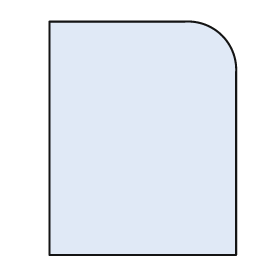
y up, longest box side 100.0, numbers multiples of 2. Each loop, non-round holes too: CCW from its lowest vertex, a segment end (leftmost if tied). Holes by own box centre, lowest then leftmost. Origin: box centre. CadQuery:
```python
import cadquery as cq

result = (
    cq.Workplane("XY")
    .moveTo(-40.0, -50.0)
    .lineTo(40.0, -50.0)
    .lineTo(40.0, 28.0)
    .threePointArc((34.0, 44.0), (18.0, 50.0))
    .lineTo(-40.0, 50.0)
    .close()
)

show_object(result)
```